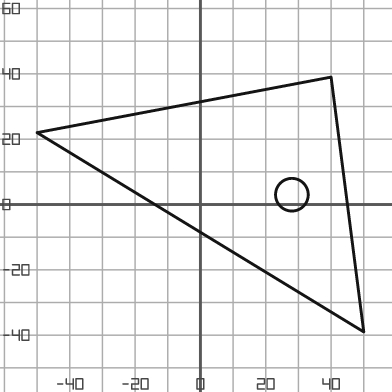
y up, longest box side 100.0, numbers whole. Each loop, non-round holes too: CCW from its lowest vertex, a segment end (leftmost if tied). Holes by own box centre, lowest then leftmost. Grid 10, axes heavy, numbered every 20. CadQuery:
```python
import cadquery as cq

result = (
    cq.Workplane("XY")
    .moveTo(50.0, -39.0)
    .lineTo(40.0, 39.0)
    .lineTo(-50.0, 22.0)
    .close()
    .moveTo(28.0, 3.0)
    .circle(5.0)
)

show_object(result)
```